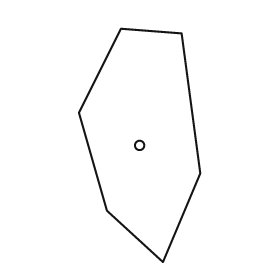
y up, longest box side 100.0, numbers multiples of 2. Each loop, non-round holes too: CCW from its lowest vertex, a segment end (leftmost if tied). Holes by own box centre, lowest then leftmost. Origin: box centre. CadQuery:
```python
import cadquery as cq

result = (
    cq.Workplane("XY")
    .moveTo(10.0, -50.0)
    .lineTo(26.0, -12.0)
    .lineTo(18.0, 48.0)
    .lineTo(-8.0, 50.0)
    .lineTo(-26.0, 14.0)
    .lineTo(-14.0, -28.0)
    .close()
    .moveTo(0.0, 0.0)
    .circle(2.0)
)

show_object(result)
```